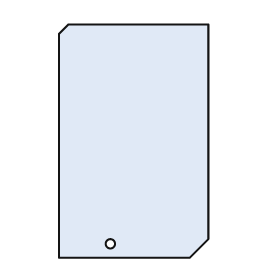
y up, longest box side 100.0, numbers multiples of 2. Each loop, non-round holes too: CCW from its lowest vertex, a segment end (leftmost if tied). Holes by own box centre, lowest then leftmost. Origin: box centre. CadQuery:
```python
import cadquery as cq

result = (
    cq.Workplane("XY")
    .moveTo(-32.0, -50.0)
    .lineTo(24.0, -50.0)
    .lineTo(32.0, -42.0)
    .lineTo(32.0, 50.0)
    .lineTo(-28.0, 50.0)
    .lineTo(-32.0, 46.0)
    .close()
    .moveTo(-10.0, -44.0)
    .circle(2.0)
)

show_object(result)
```